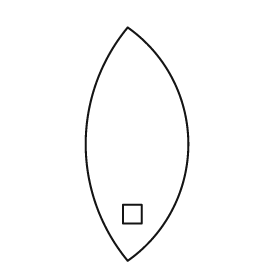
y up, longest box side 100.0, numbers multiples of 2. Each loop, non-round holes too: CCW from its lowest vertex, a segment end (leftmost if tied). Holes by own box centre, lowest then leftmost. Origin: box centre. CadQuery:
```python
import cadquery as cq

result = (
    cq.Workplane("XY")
    .moveTo(-4.0, -50.0)
    .threePointArc((22.0, 0.0), (-4.0, 50.0))
    .threePointArc((-22.0, 0.0), (-4.0, -50.0))
    .close()
    .moveTo(-6.0, -34.0)
    .lineTo(2.0, -34.0)
    .lineTo(2.0, -26.0)
    .lineTo(-6.0, -26.0)
    .close()
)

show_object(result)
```